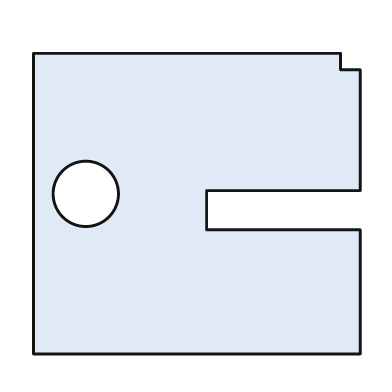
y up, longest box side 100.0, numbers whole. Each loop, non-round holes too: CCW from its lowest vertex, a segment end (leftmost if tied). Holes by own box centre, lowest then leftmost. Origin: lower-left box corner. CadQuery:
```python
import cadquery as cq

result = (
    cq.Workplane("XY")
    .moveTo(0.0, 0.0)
    .lineTo(100.0, 0.0)
    .lineTo(100.0, 38.0)
    .lineTo(53.0, 38.0)
    .lineTo(53.0, 50.0)
    .lineTo(100.0, 50.0)
    .lineTo(100.0, 87.0)
    .lineTo(94.0, 87.0)
    .lineTo(94.0, 92.0)
    .lineTo(0.0, 92.0)
    .close()
    .moveTo(16.0, 49.0)
    .circle(10.0)
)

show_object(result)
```